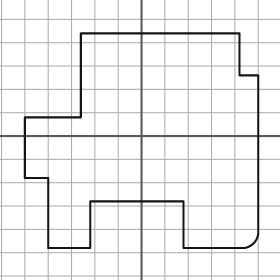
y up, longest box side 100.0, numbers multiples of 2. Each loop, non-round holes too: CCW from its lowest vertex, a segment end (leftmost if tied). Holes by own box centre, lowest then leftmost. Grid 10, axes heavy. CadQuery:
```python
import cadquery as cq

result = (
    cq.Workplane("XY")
    .moveTo(-40.0, -48.0)
    .lineTo(-22.0, -48.0)
    .lineTo(-22.0, -28.0)
    .lineTo(18.0, -28.0)
    .lineTo(18.0, -48.0)
    .lineTo(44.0, -48.0)
    .threePointArc((48.0, -46.0), (50.0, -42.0))
    .lineTo(50.0, 26.0)
    .lineTo(42.0, 26.0)
    .lineTo(42.0, 44.0)
    .lineTo(-26.0, 44.0)
    .lineTo(-26.0, 8.0)
    .lineTo(-50.0, 8.0)
    .lineTo(-50.0, -18.0)
    .lineTo(-40.0, -18.0)
    .close()
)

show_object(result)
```